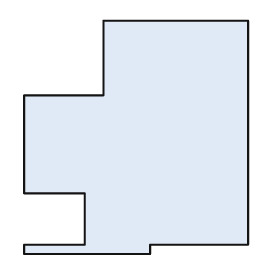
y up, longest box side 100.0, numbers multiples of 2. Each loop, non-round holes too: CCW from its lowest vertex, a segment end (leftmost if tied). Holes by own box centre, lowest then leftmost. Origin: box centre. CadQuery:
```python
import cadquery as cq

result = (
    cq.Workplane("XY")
    .moveTo(-48.0, -50.0)
    .lineTo(6.0, -50.0)
    .lineTo(6.0, -46.0)
    .lineTo(48.0, -46.0)
    .lineTo(48.0, 50.0)
    .lineTo(-14.0, 50.0)
    .lineTo(-14.0, 18.0)
    .lineTo(-48.0, 18.0)
    .lineTo(-48.0, -24.0)
    .lineTo(-22.0, -24.0)
    .lineTo(-22.0, -46.0)
    .lineTo(-48.0, -46.0)
    .close()
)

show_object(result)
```